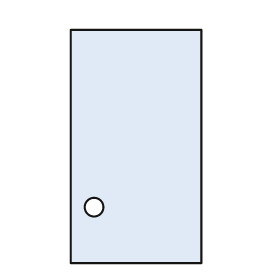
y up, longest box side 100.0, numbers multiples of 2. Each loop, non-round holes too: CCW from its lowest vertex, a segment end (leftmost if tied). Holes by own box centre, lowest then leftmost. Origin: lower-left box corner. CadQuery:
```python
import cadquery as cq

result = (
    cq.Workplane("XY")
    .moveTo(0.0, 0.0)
    .lineTo(56.0, 0.0)
    .lineTo(56.0, 100.0)
    .lineTo(0.0, 100.0)
    .close()
    .moveTo(10.0, 24.0)
    .circle(4.0)
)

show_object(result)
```